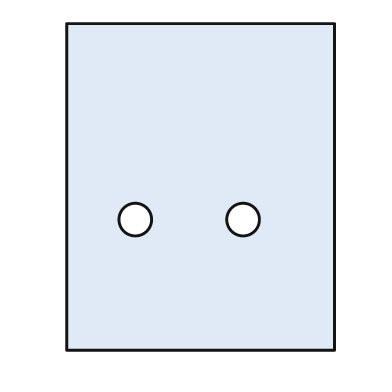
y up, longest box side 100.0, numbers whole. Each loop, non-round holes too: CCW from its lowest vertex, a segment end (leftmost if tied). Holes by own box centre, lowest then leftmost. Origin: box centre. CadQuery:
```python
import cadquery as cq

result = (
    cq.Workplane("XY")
    .moveTo(-41.0, -50.0)
    .lineTo(41.0, -50.0)
    .lineTo(41.0, 50.0)
    .lineTo(-41.0, 50.0)
    .close()
    .moveTo(-20.0, -10.0)
    .circle(5.0)
    .moveTo(13.0, -10.0)
    .circle(5.0)
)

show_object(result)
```